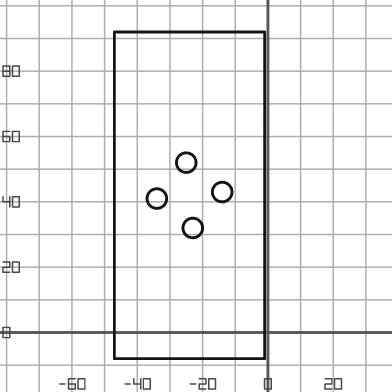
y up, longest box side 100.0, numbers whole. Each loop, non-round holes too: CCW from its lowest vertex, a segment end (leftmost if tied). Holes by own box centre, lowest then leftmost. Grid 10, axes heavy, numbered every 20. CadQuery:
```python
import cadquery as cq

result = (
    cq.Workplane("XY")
    .moveTo(-47.0, -8.0)
    .lineTo(-1.0, -8.0)
    .lineTo(-1.0, 92.0)
    .lineTo(-47.0, 92.0)
    .close()
    .moveTo(-23.0, 32.0)
    .circle(3.0)
    .moveTo(-34.0, 41.0)
    .circle(3.0)
    .moveTo(-14.0, 43.0)
    .circle(3.0)
    .moveTo(-25.0, 52.0)
    .circle(3.0)
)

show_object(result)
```